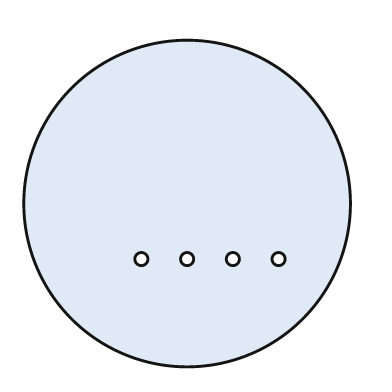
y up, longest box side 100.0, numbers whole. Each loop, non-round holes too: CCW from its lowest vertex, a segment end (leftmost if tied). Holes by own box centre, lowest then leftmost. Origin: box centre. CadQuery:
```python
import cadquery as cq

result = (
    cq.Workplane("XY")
    .moveTo(0.0, 0.0)
    .circle(50.0)
    .moveTo(-14.0, -17.0)
    .circle(2.0)
    .moveTo(0.0, -17.0)
    .circle(2.0)
    .moveTo(14.0, -17.0)
    .circle(2.0)
    .moveTo(28.0, -17.0)
    .circle(2.0)
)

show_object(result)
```